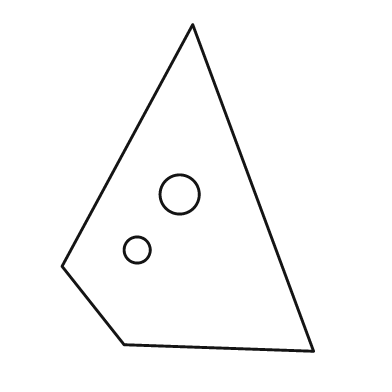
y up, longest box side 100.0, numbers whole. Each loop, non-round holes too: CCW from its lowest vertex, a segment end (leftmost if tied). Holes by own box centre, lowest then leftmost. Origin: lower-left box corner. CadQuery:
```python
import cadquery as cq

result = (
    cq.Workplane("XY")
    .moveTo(77.0, 0.0)
    .lineTo(40.0, 100.0)
    .lineTo(0.0, 26.0)
    .lineTo(19.0, 2.0)
    .close()
    .moveTo(23.0, 31.0)
    .circle(4.0)
    .moveTo(36.0, 48.0)
    .circle(6.0)
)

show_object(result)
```